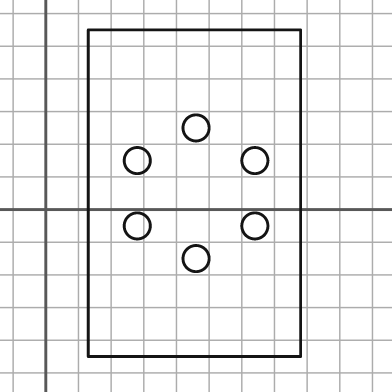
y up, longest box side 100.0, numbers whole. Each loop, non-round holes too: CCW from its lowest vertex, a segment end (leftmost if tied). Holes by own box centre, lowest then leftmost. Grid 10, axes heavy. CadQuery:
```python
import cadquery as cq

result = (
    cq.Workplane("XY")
    .moveTo(13.0, -45.0)
    .lineTo(78.0, -45.0)
    .lineTo(78.0, 55.0)
    .lineTo(13.0, 55.0)
    .close()
    .moveTo(46.0, -15.0)
    .circle(4.0)
    .moveTo(28.0, -5.0)
    .circle(4.0)
    .moveTo(64.0, -5.0)
    .circle(4.0)
    .moveTo(28.0, 15.0)
    .circle(4.0)
    .moveTo(64.0, 15.0)
    .circle(4.0)
    .moveTo(46.0, 25.0)
    .circle(4.0)
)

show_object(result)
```